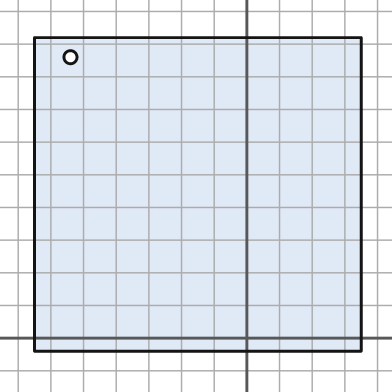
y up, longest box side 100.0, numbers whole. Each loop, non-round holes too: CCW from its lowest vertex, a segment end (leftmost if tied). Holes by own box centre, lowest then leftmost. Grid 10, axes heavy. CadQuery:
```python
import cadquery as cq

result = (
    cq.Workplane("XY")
    .moveTo(-65.0, -4.0)
    .lineTo(35.0, -4.0)
    .lineTo(35.0, 92.0)
    .lineTo(-65.0, 92.0)
    .close()
    .moveTo(-54.0, 86.0)
    .circle(2.0)
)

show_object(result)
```